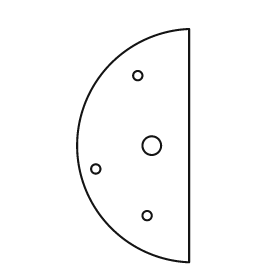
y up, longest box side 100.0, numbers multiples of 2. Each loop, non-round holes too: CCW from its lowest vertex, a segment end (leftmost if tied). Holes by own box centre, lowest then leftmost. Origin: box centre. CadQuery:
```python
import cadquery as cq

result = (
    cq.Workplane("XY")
    .moveTo(24.0, -50.0)
    .lineTo(24.0, 50.0)
    .threePointArc((-24.0, 0.0), (24.0, -50.0))
    .close()
    .moveTo(6.0, -30.0)
    .circle(2.0)
    .moveTo(-16.0, -10.0)
    .circle(2.0)
    .moveTo(8.0, 0.0)
    .circle(4.0)
    .moveTo(2.0, 30.0)
    .circle(2.0)
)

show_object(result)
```